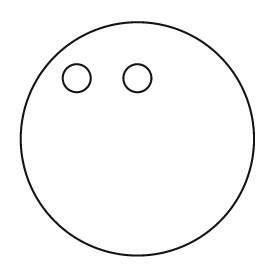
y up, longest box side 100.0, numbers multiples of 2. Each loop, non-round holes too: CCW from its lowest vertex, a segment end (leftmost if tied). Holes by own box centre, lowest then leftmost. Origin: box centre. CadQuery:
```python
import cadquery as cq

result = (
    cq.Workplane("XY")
    .moveTo(0.0, 0.0)
    .circle(50.0)
    .moveTo(-26.0, 26.0)
    .circle(6.0)
    .moveTo(0.0, 26.0)
    .circle(6.0)
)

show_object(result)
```